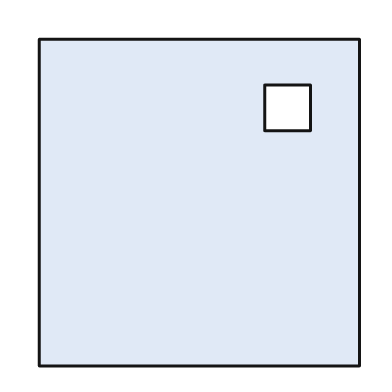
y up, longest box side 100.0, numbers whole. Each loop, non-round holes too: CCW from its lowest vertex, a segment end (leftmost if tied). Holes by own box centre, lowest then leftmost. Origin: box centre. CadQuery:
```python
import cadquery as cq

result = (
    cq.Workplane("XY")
    .moveTo(-49.0, -50.0)
    .lineTo(49.0, -50.0)
    .lineTo(49.0, 50.0)
    .lineTo(-49.0, 50.0)
    .close()
    .moveTo(20.0, 22.0)
    .lineTo(34.0, 22.0)
    .lineTo(34.0, 36.0)
    .lineTo(20.0, 36.0)
    .close()
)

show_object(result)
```